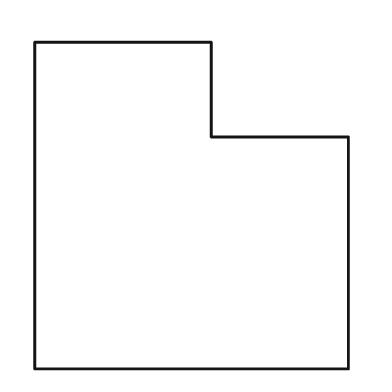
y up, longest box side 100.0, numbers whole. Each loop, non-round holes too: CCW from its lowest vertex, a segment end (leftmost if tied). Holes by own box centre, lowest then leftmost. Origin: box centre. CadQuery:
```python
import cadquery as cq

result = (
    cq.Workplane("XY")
    .moveTo(-48.0, -50.0)
    .lineTo(48.0, -50.0)
    .lineTo(48.0, 21.0)
    .lineTo(6.0, 21.0)
    .lineTo(6.0, 50.0)
    .lineTo(-48.0, 50.0)
    .close()
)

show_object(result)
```